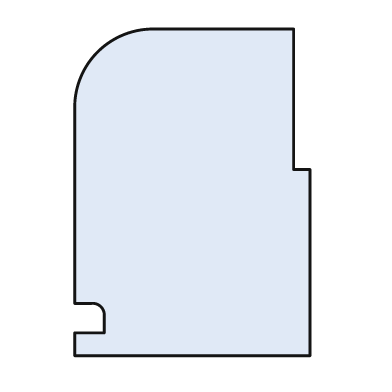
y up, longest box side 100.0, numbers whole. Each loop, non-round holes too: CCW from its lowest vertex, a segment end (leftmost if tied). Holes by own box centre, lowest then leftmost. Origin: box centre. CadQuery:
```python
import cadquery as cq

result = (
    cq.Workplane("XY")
    .moveTo(-36.0, -50.0)
    .lineTo(36.0, -50.0)
    .lineTo(36.0, 7.0)
    .lineTo(31.0, 7.0)
    .lineTo(31.0, 50.0)
    .lineTo(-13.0, 50.0)
    .threePointArc((-29.0, 43.0), (-36.0, 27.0))
    .lineTo(-36.0, -34.0)
    .lineTo(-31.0, -34.0)
    .threePointArc((-28.0, -35.0), (-27.0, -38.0))
    .lineTo(-27.0, -43.0)
    .lineTo(-36.0, -43.0)
    .close()
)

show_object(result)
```